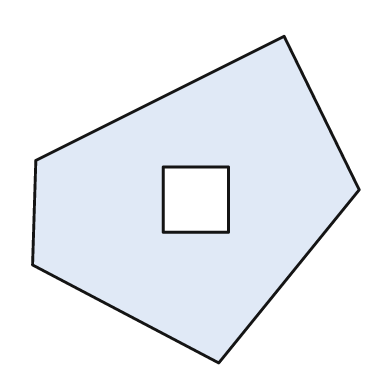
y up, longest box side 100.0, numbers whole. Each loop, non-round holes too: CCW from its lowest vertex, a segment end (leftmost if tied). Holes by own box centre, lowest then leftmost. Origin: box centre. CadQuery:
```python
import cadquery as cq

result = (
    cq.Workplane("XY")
    .moveTo(7.0, -50.0)
    .lineTo(50.0, 3.0)
    .lineTo(27.0, 50.0)
    .lineTo(-49.0, 12.0)
    .lineTo(-50.0, -20.0)
    .close()
    .moveTo(-10.0, -10.0)
    .lineTo(10.0, -10.0)
    .lineTo(10.0, 10.0)
    .lineTo(-10.0, 10.0)
    .close()
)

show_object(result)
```